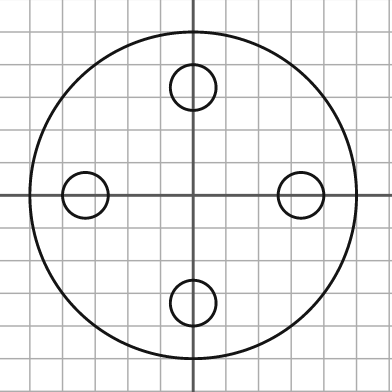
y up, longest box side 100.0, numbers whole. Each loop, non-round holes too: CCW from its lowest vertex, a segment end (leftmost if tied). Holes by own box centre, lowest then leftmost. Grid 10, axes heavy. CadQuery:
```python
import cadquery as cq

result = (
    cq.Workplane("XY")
    .moveTo(0.0, 0.0)
    .circle(50.0)
    .moveTo(0.0, -33.0)
    .circle(7.0)
    .moveTo(-33.0, 0.0)
    .circle(7.0)
    .moveTo(33.0, 0.0)
    .circle(7.0)
    .moveTo(0.0, 33.0)
    .circle(7.0)
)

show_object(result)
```